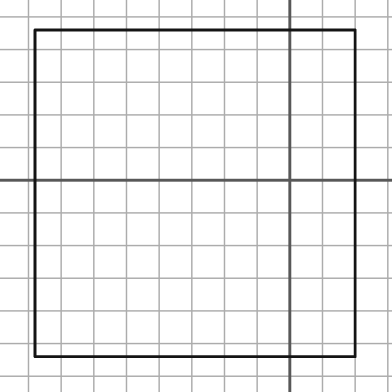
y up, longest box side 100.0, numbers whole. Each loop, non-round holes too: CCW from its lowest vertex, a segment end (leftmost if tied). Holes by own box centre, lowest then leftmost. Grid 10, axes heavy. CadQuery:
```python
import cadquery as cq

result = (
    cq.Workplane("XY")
    .moveTo(-78.0, -54.0)
    .lineTo(20.0, -54.0)
    .lineTo(20.0, 46.0)
    .lineTo(-78.0, 46.0)
    .close()
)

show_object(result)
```